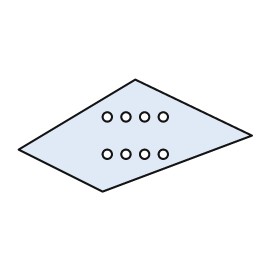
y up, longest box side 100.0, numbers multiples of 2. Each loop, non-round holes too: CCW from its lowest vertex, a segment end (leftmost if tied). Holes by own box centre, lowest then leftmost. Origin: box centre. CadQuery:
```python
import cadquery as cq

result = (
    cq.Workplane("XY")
    .moveTo(-14.0, -24.0)
    .lineTo(50.0, 0.0)
    .lineTo(0.0, 24.0)
    .lineTo(-50.0, -6.0)
    .close()
    .moveTo(-12.0, -8.0)
    .circle(2.0)
    .moveTo(-4.0, -8.0)
    .circle(2.0)
    .moveTo(4.0, -8.0)
    .circle(2.0)
    .moveTo(12.0, -8.0)
    .circle(2.0)
    .moveTo(-12.0, 8.0)
    .circle(2.0)
    .moveTo(-4.0, 8.0)
    .circle(2.0)
    .moveTo(4.0, 8.0)
    .circle(2.0)
    .moveTo(12.0, 8.0)
    .circle(2.0)
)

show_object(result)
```